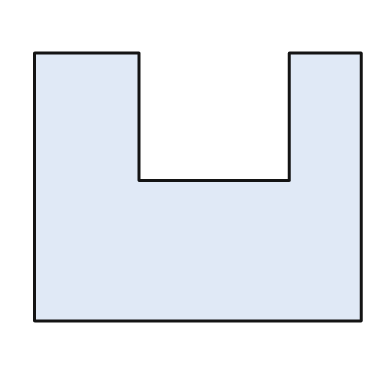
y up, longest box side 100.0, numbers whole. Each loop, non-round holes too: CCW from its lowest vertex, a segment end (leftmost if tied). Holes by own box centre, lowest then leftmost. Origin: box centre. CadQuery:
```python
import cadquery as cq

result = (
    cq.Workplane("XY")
    .moveTo(-50.0, -41.0)
    .lineTo(50.0, -41.0)
    .lineTo(50.0, 41.0)
    .lineTo(28.0, 41.0)
    .lineTo(28.0, 2.0)
    .lineTo(-18.0, 2.0)
    .lineTo(-18.0, 41.0)
    .lineTo(-50.0, 41.0)
    .close()
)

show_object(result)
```